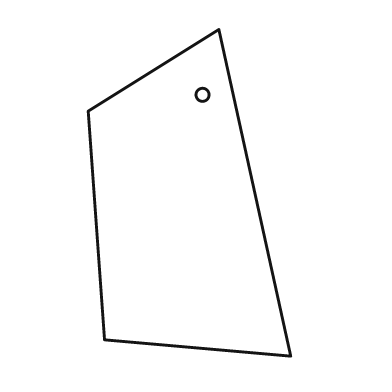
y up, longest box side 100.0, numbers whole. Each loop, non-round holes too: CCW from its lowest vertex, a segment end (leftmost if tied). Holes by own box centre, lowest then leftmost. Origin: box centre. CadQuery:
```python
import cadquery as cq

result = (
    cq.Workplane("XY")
    .moveTo(31.0, -50.0)
    .lineTo(9.0, 50.0)
    .lineTo(-31.0, 25.0)
    .lineTo(-26.0, -45.0)
    .close()
    .moveTo(4.0, 30.0)
    .circle(2.0)
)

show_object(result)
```